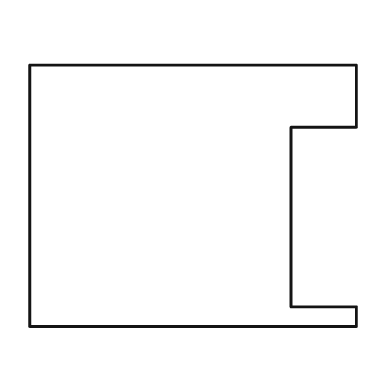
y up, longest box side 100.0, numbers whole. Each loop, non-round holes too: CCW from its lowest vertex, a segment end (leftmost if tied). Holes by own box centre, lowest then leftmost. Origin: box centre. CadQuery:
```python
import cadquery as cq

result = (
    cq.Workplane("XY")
    .moveTo(-50.0, -40.0)
    .lineTo(50.0, -40.0)
    .lineTo(50.0, -34.0)
    .lineTo(30.0, -34.0)
    .lineTo(30.0, 21.0)
    .lineTo(50.0, 21.0)
    .lineTo(50.0, 40.0)
    .lineTo(-50.0, 40.0)
    .close()
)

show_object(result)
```